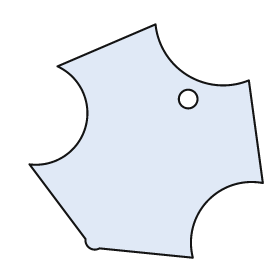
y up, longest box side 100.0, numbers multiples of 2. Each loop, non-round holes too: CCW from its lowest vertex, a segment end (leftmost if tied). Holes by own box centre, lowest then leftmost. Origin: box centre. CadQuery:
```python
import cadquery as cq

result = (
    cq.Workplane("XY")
    .moveTo(20.0, -50.0)
    .threePointArc((26.0, -26.0), (50.0, -18.0))
    .lineTo(44.0, 26.0)
    .threePointArc((18.0, 28.0), (4.0, 50.0))
    .lineTo(-38.0, 32.0)
    .threePointArc((-26.0, 6.0), (-50.0, -10.0))
    .lineTo(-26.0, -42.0)
    .threePointArc((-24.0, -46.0), (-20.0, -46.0))
    .close()
    .moveTo(18.0, 18.0)
    .circle(4.0)
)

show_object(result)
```